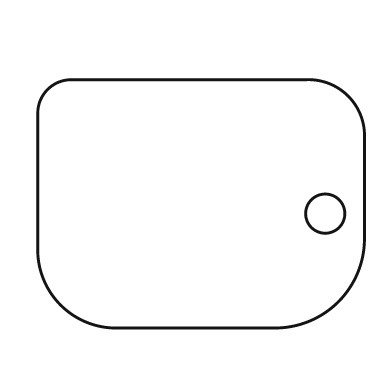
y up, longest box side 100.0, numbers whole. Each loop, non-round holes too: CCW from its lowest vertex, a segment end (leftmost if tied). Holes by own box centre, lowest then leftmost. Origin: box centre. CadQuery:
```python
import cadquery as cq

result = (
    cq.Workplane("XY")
    .moveTo(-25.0, -38.0)
    .lineTo(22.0, -38.0)
    .threePointArc((42.0, -30.0), (50.0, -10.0))
    .lineTo(50.0, 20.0)
    .threePointArc((45.0, 33.0), (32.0, 38.0))
    .lineTo(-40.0, 38.0)
    .threePointArc((-47.0, 35.0), (-50.0, 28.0))
    .lineTo(-50.0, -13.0)
    .threePointArc((-43.0, -31.0), (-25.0, -38.0))
    .close()
    .moveTo(38.0, -3.0)
    .circle(6.0)
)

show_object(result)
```